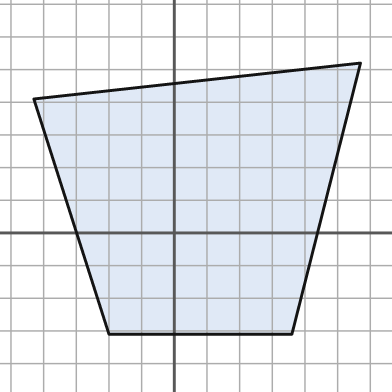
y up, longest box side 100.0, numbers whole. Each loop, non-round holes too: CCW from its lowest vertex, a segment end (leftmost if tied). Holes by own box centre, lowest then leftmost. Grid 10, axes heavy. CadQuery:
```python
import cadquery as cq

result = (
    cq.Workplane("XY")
    .moveTo(-20.0, -31.0)
    .lineTo(36.0, -31.0)
    .lineTo(57.0, 52.0)
    .lineTo(-43.0, 41.0)
    .close()
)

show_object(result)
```